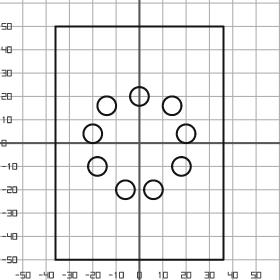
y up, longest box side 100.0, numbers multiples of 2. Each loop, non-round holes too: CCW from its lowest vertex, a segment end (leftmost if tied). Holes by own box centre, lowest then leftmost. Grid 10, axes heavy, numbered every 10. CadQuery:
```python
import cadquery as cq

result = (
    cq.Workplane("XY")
    .moveTo(-36.0, -50.0)
    .lineTo(36.0, -50.0)
    .lineTo(36.0, 50.0)
    .lineTo(-36.0, 50.0)
    .close()
    .moveTo(-6.0, -20.0)
    .circle(4.0)
    .moveTo(6.0, -20.0)
    .circle(4.0)
    .moveTo(-18.0, -10.0)
    .circle(4.0)
    .moveTo(18.0, -10.0)
    .circle(4.0)
    .moveTo(-20.0, 4.0)
    .circle(4.0)
    .moveTo(20.0, 4.0)
    .circle(4.0)
    .moveTo(-14.0, 16.0)
    .circle(4.0)
    .moveTo(14.0, 16.0)
    .circle(4.0)
    .moveTo(0.0, 20.0)
    .circle(4.0)
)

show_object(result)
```